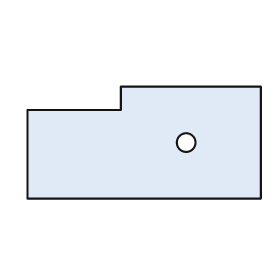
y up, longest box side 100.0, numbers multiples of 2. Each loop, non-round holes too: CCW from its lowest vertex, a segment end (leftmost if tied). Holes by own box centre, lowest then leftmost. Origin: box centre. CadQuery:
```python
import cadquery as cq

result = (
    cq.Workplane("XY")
    .moveTo(-50.0, -24.0)
    .lineTo(50.0, -24.0)
    .lineTo(50.0, 24.0)
    .lineTo(-10.0, 24.0)
    .lineTo(-10.0, 14.0)
    .lineTo(-50.0, 14.0)
    .close()
    .moveTo(18.0, 0.0)
    .circle(4.0)
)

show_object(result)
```